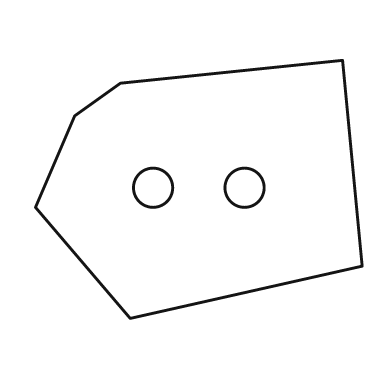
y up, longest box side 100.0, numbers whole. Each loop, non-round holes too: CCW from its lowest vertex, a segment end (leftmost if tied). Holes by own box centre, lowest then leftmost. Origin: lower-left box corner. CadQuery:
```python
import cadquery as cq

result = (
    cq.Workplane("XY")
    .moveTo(29.0, 0.0)
    .lineTo(100.0, 16.0)
    .lineTo(94.0, 79.0)
    .lineTo(26.0, 72.0)
    .lineTo(12.0, 62.0)
    .lineTo(0.0, 34.0)
    .close()
    .moveTo(36.0, 40.0)
    .circle(6.0)
    .moveTo(64.0, 40.0)
    .circle(6.0)
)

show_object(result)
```